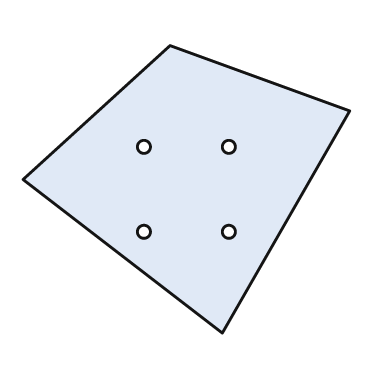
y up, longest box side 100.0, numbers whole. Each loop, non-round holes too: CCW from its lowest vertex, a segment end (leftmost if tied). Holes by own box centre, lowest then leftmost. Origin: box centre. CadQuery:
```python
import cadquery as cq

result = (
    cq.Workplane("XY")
    .moveTo(11.0, -44.0)
    .lineTo(50.0, 24.0)
    .lineTo(-5.0, 44.0)
    .lineTo(-50.0, 3.0)
    .close()
    .moveTo(-13.0, -13.0)
    .circle(2.0)
    .moveTo(13.0, -13.0)
    .circle(2.0)
    .moveTo(-13.0, 13.0)
    .circle(2.0)
    .moveTo(13.0, 13.0)
    .circle(2.0)
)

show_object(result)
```